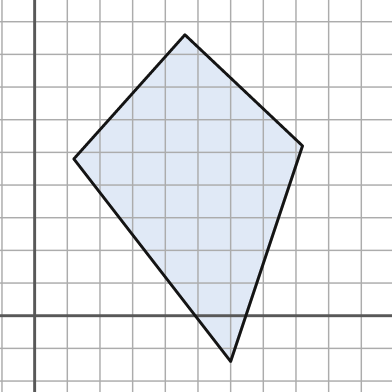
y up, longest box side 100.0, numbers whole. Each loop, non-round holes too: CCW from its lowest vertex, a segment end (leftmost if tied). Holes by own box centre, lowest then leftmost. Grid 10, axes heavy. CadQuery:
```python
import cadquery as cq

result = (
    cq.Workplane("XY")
    .moveTo(60.0, -14.0)
    .lineTo(82.0, 52.0)
    .lineTo(46.0, 86.0)
    .lineTo(12.0, 48.0)
    .close()
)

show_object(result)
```